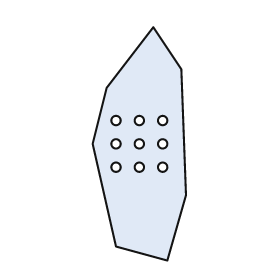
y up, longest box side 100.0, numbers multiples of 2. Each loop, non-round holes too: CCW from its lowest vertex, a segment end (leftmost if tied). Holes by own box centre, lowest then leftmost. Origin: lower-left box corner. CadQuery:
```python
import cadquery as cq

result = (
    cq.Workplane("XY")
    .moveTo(32.0, 0.0)
    .lineTo(40.0, 28.0)
    .lineTo(38.0, 82.0)
    .lineTo(26.0, 100.0)
    .lineTo(6.0, 74.0)
    .lineTo(0.0, 50.0)
    .lineTo(10.0, 6.0)
    .close()
    .moveTo(10.0, 40.0)
    .circle(2.0)
    .moveTo(20.0, 40.0)
    .circle(2.0)
    .moveTo(30.0, 40.0)
    .circle(2.0)
    .moveTo(10.0, 50.0)
    .circle(2.0)
    .moveTo(20.0, 50.0)
    .circle(2.0)
    .moveTo(30.0, 50.0)
    .circle(2.0)
    .moveTo(10.0, 60.0)
    .circle(2.0)
    .moveTo(20.0, 60.0)
    .circle(2.0)
    .moveTo(30.0, 60.0)
    .circle(2.0)
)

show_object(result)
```